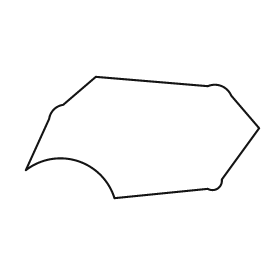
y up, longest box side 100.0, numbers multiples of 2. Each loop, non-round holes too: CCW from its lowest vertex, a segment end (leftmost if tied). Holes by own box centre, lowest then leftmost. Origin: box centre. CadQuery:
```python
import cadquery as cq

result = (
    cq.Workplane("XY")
    .moveTo(-12.0, -26.0)
    .lineTo(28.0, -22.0)
    .threePointArc((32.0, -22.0), (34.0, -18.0))
    .lineTo(50.0, 4.0)
    .lineTo(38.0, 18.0)
    .threePointArc((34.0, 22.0), (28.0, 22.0))
    .lineTo(-20.0, 26.0)
    .lineTo(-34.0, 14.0)
    .threePointArc((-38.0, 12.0), (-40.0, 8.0))
    .lineTo(-50.0, -14.0)
    .threePointArc((-28.0, -10.0), (-12.0, -26.0))
    .close()
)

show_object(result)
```